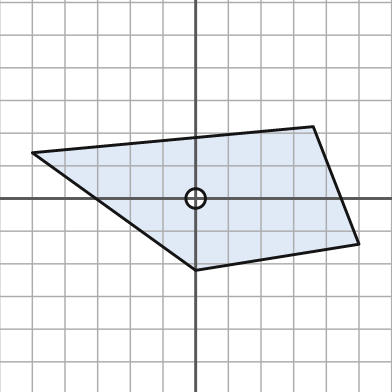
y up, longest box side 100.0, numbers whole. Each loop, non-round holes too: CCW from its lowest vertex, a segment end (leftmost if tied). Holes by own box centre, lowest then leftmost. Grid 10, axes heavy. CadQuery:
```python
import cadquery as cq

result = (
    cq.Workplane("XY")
    .moveTo(0.0, -22.0)
    .lineTo(50.0, -14.0)
    .lineTo(36.0, 22.0)
    .lineTo(-50.0, 14.0)
    .close()
    .moveTo(0.0, 0.0)
    .circle(3.0)
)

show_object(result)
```